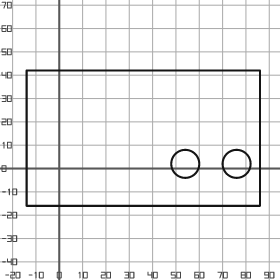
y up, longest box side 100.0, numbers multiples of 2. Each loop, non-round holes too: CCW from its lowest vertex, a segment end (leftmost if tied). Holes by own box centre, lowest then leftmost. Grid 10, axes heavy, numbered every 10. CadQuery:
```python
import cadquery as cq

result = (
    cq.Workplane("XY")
    .moveTo(-14.0, -16.0)
    .lineTo(86.0, -16.0)
    .lineTo(86.0, 42.0)
    .lineTo(-14.0, 42.0)
    .close()
    .moveTo(54.0, 2.0)
    .circle(6.0)
    .moveTo(76.0, 2.0)
    .circle(6.0)
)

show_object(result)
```